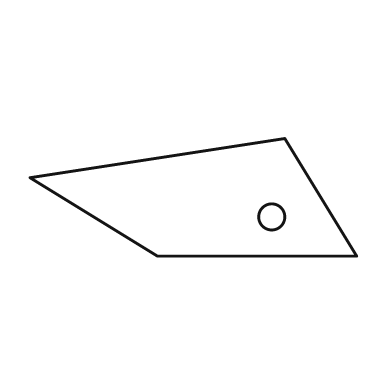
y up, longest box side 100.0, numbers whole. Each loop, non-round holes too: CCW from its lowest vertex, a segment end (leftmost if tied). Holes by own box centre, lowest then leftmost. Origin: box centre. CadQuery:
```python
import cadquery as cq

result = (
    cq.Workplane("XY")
    .moveTo(-11.0, -18.0)
    .lineTo(50.0, -18.0)
    .lineTo(28.0, 18.0)
    .lineTo(-50.0, 6.0)
    .close()
    .moveTo(24.0, -6.0)
    .circle(4.0)
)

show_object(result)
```